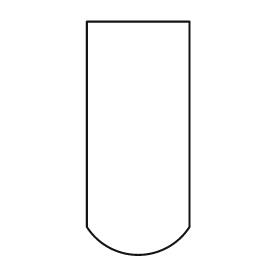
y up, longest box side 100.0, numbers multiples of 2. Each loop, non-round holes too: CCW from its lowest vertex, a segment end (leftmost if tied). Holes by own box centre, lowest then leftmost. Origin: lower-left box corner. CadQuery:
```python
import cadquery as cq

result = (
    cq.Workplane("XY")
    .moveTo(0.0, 12.0)
    .threePointArc((22.0, 0.0), (44.0, 12.0))
    .lineTo(44.0, 100.0)
    .lineTo(0.0, 100.0)
    .close()
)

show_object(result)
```